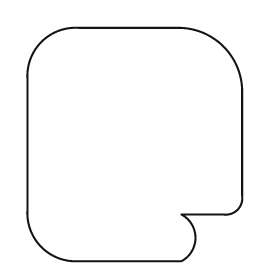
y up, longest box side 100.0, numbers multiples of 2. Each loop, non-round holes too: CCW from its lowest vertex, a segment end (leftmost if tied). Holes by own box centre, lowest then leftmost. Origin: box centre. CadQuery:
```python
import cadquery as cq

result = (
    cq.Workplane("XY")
    .moveTo(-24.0, -50.0)
    .lineTo(20.0, -50.0)
    .threePointArc((26.0, -40.0), (20.0, -30.0))
    .lineTo(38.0, -30.0)
    .threePointArc((44.0, -28.0), (46.0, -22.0))
    .lineTo(46.0, 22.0)
    .threePointArc((38.0, 42.0), (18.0, 50.0))
    .lineTo(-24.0, 50.0)
    .threePointArc((-40.0, 44.0), (-46.0, 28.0))
    .lineTo(-46.0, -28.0)
    .threePointArc((-40.0, -44.0), (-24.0, -50.0))
    .close()
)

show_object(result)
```